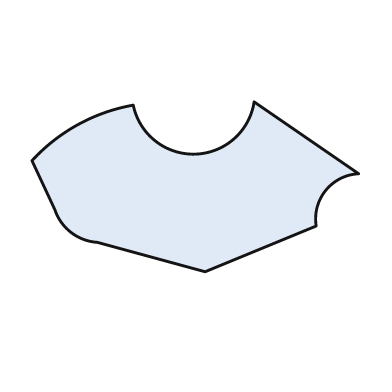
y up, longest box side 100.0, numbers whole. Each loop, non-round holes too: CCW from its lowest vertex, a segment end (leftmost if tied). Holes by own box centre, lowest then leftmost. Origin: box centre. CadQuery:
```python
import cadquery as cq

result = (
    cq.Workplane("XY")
    .moveTo(3.0, -26.0)
    .lineTo(37.0, -12.0)
    .threePointArc((40.0, -1.0), (50.0, 4.0))
    .lineTo(18.0, 26.0)
    .threePointArc((0.0, 10.0), (-19.0, 25.0))
    .threePointArc((-36.0, 19.0), (-50.0, 8.0))
    .lineTo(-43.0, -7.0)
    .threePointArc((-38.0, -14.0), (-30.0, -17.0))
    .close()
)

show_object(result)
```